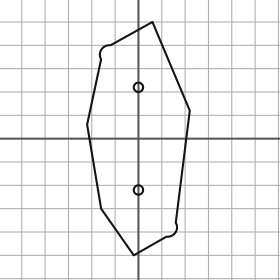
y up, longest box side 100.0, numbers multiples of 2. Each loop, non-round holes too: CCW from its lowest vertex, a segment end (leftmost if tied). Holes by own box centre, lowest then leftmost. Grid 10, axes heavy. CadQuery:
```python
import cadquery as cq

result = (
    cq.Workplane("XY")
    .moveTo(-2.0, -50.0)
    .lineTo(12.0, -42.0)
    .threePointArc((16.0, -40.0), (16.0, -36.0))
    .lineTo(22.0, 12.0)
    .lineTo(6.0, 50.0)
    .lineTo(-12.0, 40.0)
    .threePointArc((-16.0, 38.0), (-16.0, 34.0))
    .lineTo(-22.0, 6.0)
    .lineTo(-16.0, -30.0)
    .close()
    .moveTo(0.0, -22.0)
    .circle(2.0)
    .moveTo(0.0, 22.0)
    .circle(2.0)
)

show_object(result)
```